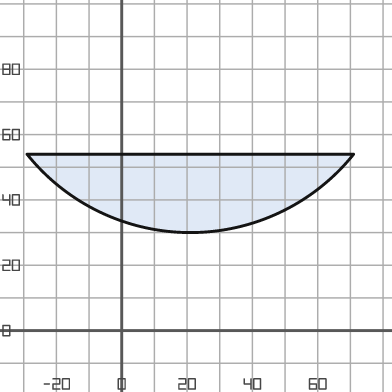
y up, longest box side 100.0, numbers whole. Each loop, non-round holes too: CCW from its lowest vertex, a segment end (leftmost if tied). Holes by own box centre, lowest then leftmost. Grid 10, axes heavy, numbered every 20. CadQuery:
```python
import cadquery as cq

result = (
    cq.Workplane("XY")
    .moveTo(-29.0, 54.0)
    .threePointArc((21.0, 30.0), (71.0, 54.0))
    .close()
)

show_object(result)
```